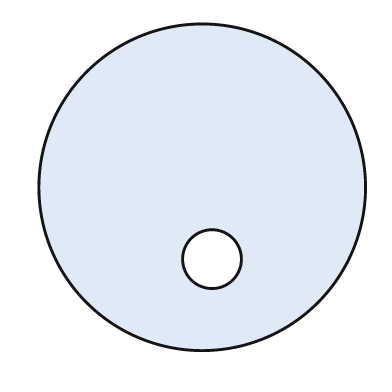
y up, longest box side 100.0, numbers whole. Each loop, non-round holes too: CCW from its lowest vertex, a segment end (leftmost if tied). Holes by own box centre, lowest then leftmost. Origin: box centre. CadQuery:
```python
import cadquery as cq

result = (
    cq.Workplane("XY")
    .moveTo(0.0, 0.0)
    .circle(50.0)
    .moveTo(3.0, -22.0)
    .circle(9.0)
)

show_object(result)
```